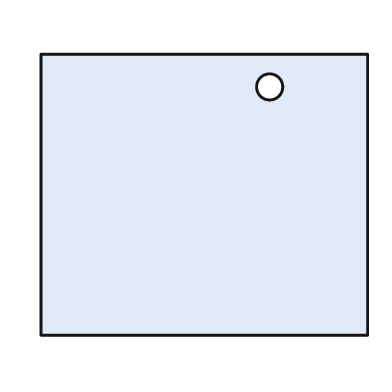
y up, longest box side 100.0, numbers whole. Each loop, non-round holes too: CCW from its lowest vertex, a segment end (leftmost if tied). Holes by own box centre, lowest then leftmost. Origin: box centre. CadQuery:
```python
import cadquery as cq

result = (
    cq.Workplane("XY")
    .moveTo(-50.0, -43.0)
    .lineTo(50.0, -43.0)
    .lineTo(50.0, 43.0)
    .lineTo(-50.0, 43.0)
    .close()
    .moveTo(20.0, 33.0)
    .circle(4.0)
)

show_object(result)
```